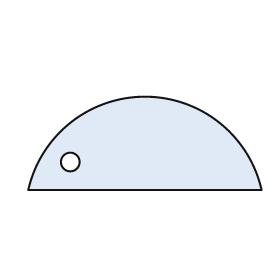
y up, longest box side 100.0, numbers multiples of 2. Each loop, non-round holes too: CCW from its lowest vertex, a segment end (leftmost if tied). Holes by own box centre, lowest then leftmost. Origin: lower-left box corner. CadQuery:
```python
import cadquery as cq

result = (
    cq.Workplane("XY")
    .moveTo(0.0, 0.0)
    .lineTo(100.0, 0.0)
    .threePointArc((50.0, 40.0), (0.0, 0.0))
    .close()
    .moveTo(18.0, 12.0)
    .circle(4.0)
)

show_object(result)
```